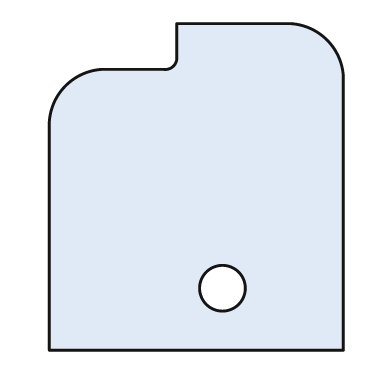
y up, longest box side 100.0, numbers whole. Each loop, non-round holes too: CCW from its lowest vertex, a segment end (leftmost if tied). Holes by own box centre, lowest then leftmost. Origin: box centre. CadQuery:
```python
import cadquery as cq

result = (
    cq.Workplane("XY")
    .moveTo(-45.0, -50.0)
    .lineTo(45.0, -50.0)
    .lineTo(45.0, 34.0)
    .threePointArc((40.0, 45.0), (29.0, 50.0))
    .lineTo(-6.0, 50.0)
    .lineTo(-6.0, 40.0)
    .threePointArc((-7.0, 37.0), (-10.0, 36.0))
    .lineTo(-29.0, 36.0)
    .threePointArc((-40.0, 31.0), (-45.0, 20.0))
    .close()
    .moveTo(8.0, -31.0)
    .circle(7.0)
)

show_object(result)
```